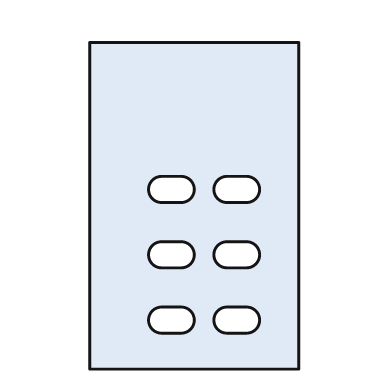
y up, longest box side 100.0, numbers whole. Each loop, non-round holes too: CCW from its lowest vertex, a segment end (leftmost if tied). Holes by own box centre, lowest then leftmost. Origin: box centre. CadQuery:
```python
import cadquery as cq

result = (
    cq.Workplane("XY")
    .moveTo(-32.0, -50.0)
    .lineTo(32.0, -50.0)
    .lineTo(32.0, 50.0)
    .lineTo(-32.0, 50.0)
    .close()
    .moveTo(-10.0, -39.0)
    .lineTo(-4.0, -39.0)
    .threePointArc((0.0, -35.0), (-4.0, -31.0))
    .lineTo(-10.0, -31.0)
    .threePointArc((-14.0, -35.0), (-10.0, -39.0))
    .close()
    .moveTo(10.0, -39.0)
    .lineTo(16.0, -39.0)
    .threePointArc((20.0, -35.0), (16.0, -31.0))
    .lineTo(10.0, -31.0)
    .threePointArc((6.0, -35.0), (10.0, -39.0))
    .close()
    .moveTo(-10.0, -19.0)
    .lineTo(-4.0, -19.0)
    .threePointArc((0.0, -15.0), (-4.0, -11.0))
    .lineTo(-10.0, -11.0)
    .threePointArc((-14.0, -15.0), (-10.0, -19.0))
    .close()
    .moveTo(10.0, -19.0)
    .lineTo(16.0, -19.0)
    .threePointArc((20.0, -15.0), (16.0, -11.0))
    .lineTo(10.0, -11.0)
    .threePointArc((6.0, -15.0), (10.0, -19.0))
    .close()
    .moveTo(-10.0, 1.0)
    .lineTo(-4.0, 1.0)
    .threePointArc((0.0, 5.0), (-4.0, 9.0))
    .lineTo(-10.0, 9.0)
    .threePointArc((-14.0, 5.0), (-10.0, 1.0))
    .close()
    .moveTo(10.0, 1.0)
    .lineTo(16.0, 1.0)
    .threePointArc((20.0, 5.0), (16.0, 9.0))
    .lineTo(10.0, 9.0)
    .threePointArc((6.0, 5.0), (10.0, 1.0))
    .close()
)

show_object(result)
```